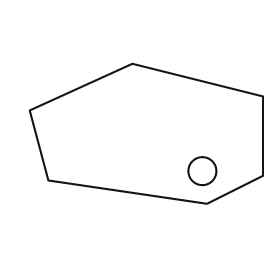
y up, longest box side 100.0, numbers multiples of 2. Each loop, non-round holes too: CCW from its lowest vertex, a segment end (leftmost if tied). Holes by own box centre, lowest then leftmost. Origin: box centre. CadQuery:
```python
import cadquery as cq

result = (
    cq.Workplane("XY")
    .moveTo(26.0, -30.0)
    .lineTo(50.0, -18.0)
    .lineTo(50.0, 16.0)
    .lineTo(-6.0, 30.0)
    .lineTo(-50.0, 10.0)
    .lineTo(-42.0, -20.0)
    .close()
    .moveTo(24.0, -16.0)
    .circle(6.0)
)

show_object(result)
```